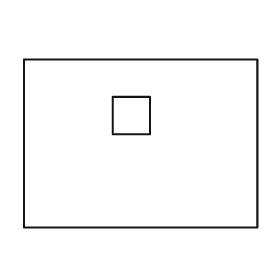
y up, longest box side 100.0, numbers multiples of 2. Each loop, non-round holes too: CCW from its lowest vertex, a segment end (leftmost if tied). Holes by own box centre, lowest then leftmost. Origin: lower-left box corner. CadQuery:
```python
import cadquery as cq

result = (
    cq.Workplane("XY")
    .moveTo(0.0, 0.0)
    .lineTo(100.0, 0.0)
    .lineTo(100.0, 72.0)
    .lineTo(0.0, 72.0)
    .close()
    .moveTo(38.0, 40.0)
    .lineTo(54.0, 40.0)
    .lineTo(54.0, 56.0)
    .lineTo(38.0, 56.0)
    .close()
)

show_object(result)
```